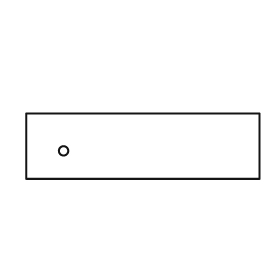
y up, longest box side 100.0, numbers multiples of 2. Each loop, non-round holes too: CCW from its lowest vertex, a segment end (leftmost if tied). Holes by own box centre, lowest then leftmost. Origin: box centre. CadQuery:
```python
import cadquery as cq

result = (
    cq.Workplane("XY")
    .moveTo(-50.0, -14.0)
    .lineTo(50.0, -14.0)
    .lineTo(50.0, 14.0)
    .lineTo(-50.0, 14.0)
    .close()
    .moveTo(-34.0, -2.0)
    .circle(2.0)
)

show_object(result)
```